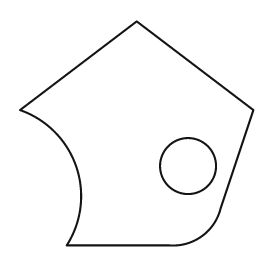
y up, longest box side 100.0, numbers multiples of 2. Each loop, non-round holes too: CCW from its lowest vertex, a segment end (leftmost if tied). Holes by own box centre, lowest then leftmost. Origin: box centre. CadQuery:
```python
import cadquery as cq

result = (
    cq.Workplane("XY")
    .moveTo(-30.0, -48.0)
    .lineTo(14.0, -48.0)
    .threePointArc((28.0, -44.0), (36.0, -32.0))
    .lineTo(50.0, 10.0)
    .lineTo(0.0, 48.0)
    .lineTo(-50.0, 10.0)
    .threePointArc((-26.0, -14.0), (-30.0, -48.0))
    .close()
    .moveTo(22.0, -14.0)
    .circle(12.0)
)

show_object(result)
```